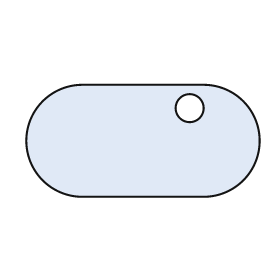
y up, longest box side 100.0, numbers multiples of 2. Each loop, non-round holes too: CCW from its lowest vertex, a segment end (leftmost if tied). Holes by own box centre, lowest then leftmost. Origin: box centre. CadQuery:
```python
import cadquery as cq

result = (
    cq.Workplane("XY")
    .moveTo(-26.0, -24.0)
    .lineTo(26.0, -24.0)
    .threePointArc((50.0, 0.0), (26.0, 24.0))
    .lineTo(-26.0, 24.0)
    .threePointArc((-50.0, 0.0), (-26.0, -24.0))
    .close()
    .moveTo(20.0, 14.0)
    .circle(6.0)
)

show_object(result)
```